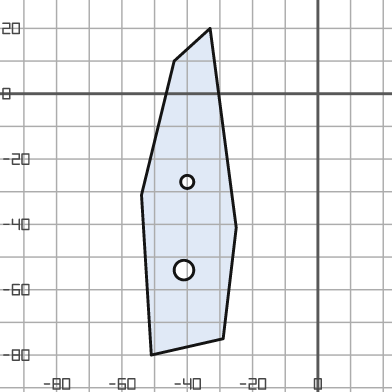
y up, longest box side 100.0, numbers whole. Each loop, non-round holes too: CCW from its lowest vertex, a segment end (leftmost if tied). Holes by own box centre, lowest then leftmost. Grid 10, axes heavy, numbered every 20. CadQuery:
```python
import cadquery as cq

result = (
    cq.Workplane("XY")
    .moveTo(-51.0, -80.0)
    .lineTo(-29.0, -75.0)
    .lineTo(-25.0, -41.0)
    .lineTo(-33.0, 20.0)
    .lineTo(-44.0, 10.0)
    .lineTo(-54.0, -31.0)
    .close()
    .moveTo(-41.0, -54.0)
    .circle(3.0)
    .moveTo(-40.0, -27.0)
    .circle(2.0)
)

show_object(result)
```